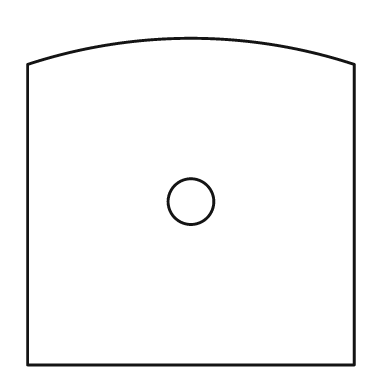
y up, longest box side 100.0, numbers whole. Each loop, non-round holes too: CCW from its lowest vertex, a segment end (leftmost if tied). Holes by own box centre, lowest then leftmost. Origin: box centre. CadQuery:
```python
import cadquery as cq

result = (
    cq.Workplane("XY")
    .moveTo(-50.0, -50.0)
    .lineTo(50.0, -50.0)
    .lineTo(50.0, 42.0)
    .threePointArc((0.0, 50.0), (-50.0, 42.0))
    .close()
    .moveTo(0.0, 0.0)
    .circle(7.0)
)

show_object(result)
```